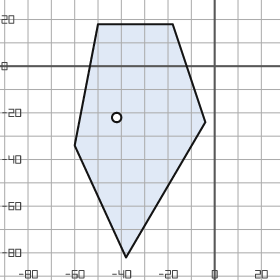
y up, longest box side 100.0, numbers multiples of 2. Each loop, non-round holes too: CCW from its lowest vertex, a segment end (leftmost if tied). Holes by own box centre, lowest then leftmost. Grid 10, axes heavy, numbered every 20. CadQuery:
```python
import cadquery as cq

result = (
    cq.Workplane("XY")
    .moveTo(-38.0, -82.0)
    .lineTo(-4.0, -24.0)
    .lineTo(-18.0, 18.0)
    .lineTo(-50.0, 18.0)
    .lineTo(-60.0, -34.0)
    .close()
    .moveTo(-42.0, -22.0)
    .circle(2.0)
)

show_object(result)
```